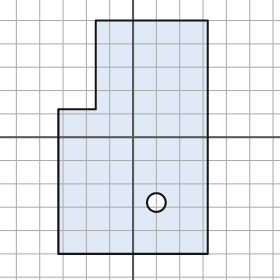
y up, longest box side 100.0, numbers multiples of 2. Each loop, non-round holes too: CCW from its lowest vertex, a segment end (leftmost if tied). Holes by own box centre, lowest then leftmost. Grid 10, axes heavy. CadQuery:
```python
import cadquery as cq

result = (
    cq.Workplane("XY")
    .moveTo(-32.0, -50.0)
    .lineTo(32.0, -50.0)
    .lineTo(32.0, 50.0)
    .lineTo(-16.0, 50.0)
    .lineTo(-16.0, 12.0)
    .lineTo(-32.0, 12.0)
    .close()
    .moveTo(10.0, -28.0)
    .circle(4.0)
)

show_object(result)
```